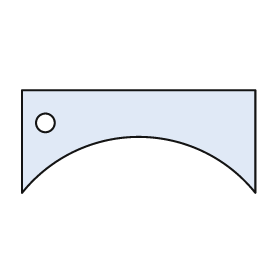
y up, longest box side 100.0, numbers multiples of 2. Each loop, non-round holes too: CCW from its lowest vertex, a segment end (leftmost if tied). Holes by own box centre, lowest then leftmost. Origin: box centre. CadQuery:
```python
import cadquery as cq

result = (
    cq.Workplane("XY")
    .moveTo(-50.0, -22.0)
    .threePointArc((0.0, 2.0), (50.0, -22.0))
    .lineTo(50.0, 22.0)
    .lineTo(-50.0, 22.0)
    .close()
    .moveTo(-40.0, 8.0)
    .circle(4.0)
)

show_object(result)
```